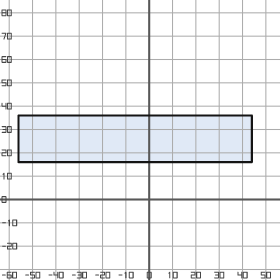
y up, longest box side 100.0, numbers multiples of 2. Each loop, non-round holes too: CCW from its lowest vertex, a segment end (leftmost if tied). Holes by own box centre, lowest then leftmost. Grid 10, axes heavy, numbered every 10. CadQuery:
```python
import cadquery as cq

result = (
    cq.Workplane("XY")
    .moveTo(-56.0, 16.0)
    .lineTo(44.0, 16.0)
    .lineTo(44.0, 36.0)
    .lineTo(-56.0, 36.0)
    .close()
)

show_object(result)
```